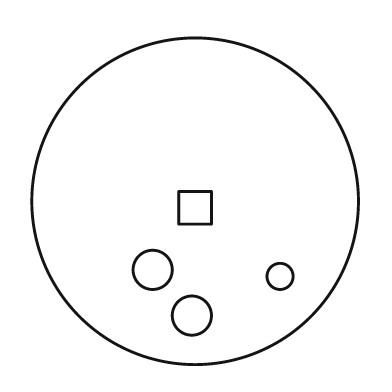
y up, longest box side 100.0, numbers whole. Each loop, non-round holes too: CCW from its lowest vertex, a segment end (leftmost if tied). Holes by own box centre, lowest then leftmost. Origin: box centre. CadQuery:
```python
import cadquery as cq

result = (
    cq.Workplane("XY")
    .moveTo(0.0, 0.0)
    .circle(50.0)
    .moveTo(-1.0, -35.0)
    .circle(6.0)
    .moveTo(26.0, -23.0)
    .circle(4.0)
    .moveTo(-13.0, -21.0)
    .circle(6.0)
    .moveTo(-5.0, -7.0)
    .lineTo(5.0, -7.0)
    .lineTo(5.0, 3.0)
    .lineTo(-5.0, 3.0)
    .close()
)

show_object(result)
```